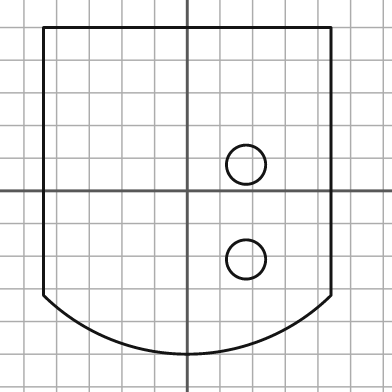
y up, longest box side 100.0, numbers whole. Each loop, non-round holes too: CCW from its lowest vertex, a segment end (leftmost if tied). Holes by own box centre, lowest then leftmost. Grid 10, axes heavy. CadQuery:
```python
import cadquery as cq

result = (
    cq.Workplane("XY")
    .moveTo(-44.0, -32.0)
    .threePointArc((0.0, -50.0), (44.0, -32.0))
    .lineTo(44.0, 50.0)
    .lineTo(-44.0, 50.0)
    .close()
    .moveTo(18.0, -21.0)
    .circle(6.0)
    .moveTo(18.0, 8.0)
    .circle(6.0)
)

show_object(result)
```